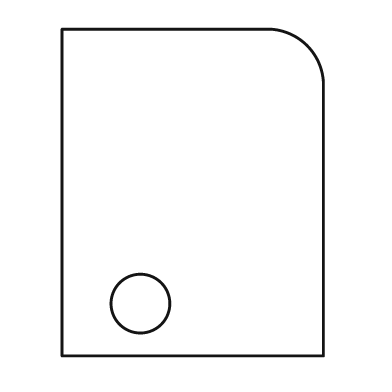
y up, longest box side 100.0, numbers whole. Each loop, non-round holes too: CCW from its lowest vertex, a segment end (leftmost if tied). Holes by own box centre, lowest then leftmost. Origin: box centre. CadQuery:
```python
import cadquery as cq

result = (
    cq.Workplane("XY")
    .moveTo(-40.0, -50.0)
    .lineTo(40.0, -50.0)
    .lineTo(40.0, 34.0)
    .threePointArc((35.0, 45.0), (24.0, 50.0))
    .lineTo(-40.0, 50.0)
    .close()
    .moveTo(-16.0, -34.0)
    .circle(9.0)
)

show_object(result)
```